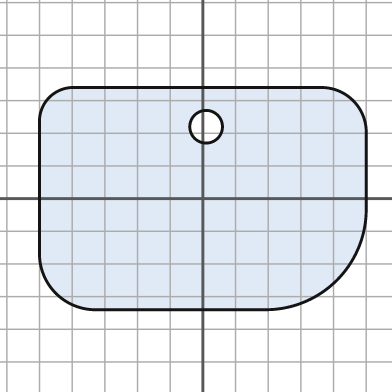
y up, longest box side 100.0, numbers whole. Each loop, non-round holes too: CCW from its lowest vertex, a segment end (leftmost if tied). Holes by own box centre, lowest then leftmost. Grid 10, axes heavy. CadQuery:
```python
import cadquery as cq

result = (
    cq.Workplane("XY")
    .moveTo(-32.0, -34.0)
    .lineTo(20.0, -34.0)
    .threePointArc((41.0, -25.0), (50.0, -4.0))
    .lineTo(50.0, 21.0)
    .threePointArc((46.0, 30.0), (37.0, 34.0))
    .lineTo(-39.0, 34.0)
    .threePointArc((-47.0, 31.0), (-50.0, 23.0))
    .lineTo(-50.0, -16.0)
    .threePointArc((-45.0, -29.0), (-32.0, -34.0))
    .close()
    .moveTo(1.0, 22.0)
    .circle(5.0)
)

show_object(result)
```